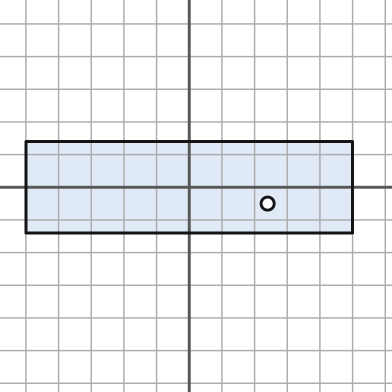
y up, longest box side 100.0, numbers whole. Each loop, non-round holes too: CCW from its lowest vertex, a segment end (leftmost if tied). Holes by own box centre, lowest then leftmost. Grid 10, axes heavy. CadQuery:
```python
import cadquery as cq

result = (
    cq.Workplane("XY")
    .moveTo(-50.0, -14.0)
    .lineTo(50.0, -14.0)
    .lineTo(50.0, 14.0)
    .lineTo(-50.0, 14.0)
    .close()
    .moveTo(24.0, -5.0)
    .circle(2.0)
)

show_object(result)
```